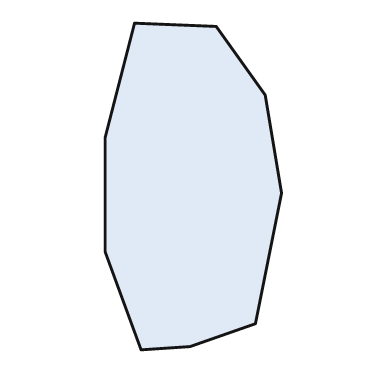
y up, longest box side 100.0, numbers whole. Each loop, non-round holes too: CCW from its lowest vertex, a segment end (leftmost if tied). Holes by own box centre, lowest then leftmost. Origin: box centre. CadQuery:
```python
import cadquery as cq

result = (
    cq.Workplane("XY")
    .moveTo(-16.0, -50.0)
    .lineTo(-1.0, -49.0)
    .lineTo(19.0, -42.0)
    .lineTo(27.0, -2.0)
    .lineTo(22.0, 28.0)
    .lineTo(7.0, 49.0)
    .lineTo(-18.0, 50.0)
    .lineTo(-27.0, 15.0)
    .lineTo(-27.0, -20.0)
    .close()
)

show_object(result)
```